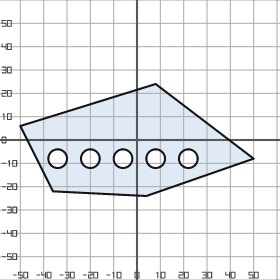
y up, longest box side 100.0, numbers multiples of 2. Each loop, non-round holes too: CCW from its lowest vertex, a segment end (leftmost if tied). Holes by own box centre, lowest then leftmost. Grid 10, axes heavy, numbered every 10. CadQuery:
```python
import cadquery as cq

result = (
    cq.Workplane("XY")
    .moveTo(4.0, -24.0)
    .lineTo(50.0, -8.0)
    .lineTo(8.0, 24.0)
    .lineTo(-50.0, 6.0)
    .lineTo(-36.0, -22.0)
    .close()
    .moveTo(-34.0, -8.0)
    .circle(4.0)
    .moveTo(-20.0, -8.0)
    .circle(4.0)
    .moveTo(-6.0, -8.0)
    .circle(4.0)
    .moveTo(8.0, -8.0)
    .circle(4.0)
    .moveTo(22.0, -8.0)
    .circle(4.0)
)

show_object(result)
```